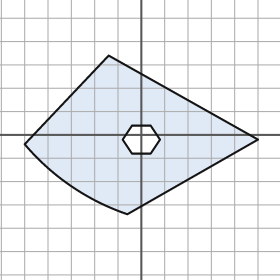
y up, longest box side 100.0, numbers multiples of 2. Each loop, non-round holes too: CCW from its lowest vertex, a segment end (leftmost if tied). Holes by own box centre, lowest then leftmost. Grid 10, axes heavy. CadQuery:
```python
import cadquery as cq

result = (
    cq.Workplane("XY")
    .moveTo(-6.0, -34.0)
    .lineTo(50.0, -2.0)
    .lineTo(-14.0, 34.0)
    .lineTo(-50.0, -4.0)
    .threePointArc((-30.0, -22.0), (-6.0, -34.0))
    .close()
    .moveTo(-4.0, -8.0)
    .lineTo(4.0, -8.0)
    .lineTo(8.0, -2.0)
    .lineTo(4.0, 4.0)
    .lineTo(-4.0, 4.0)
    .lineTo(-8.0, -2.0)
    .close()
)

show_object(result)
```